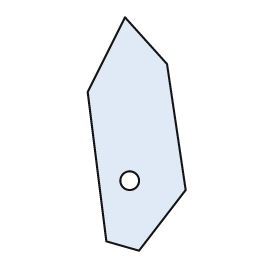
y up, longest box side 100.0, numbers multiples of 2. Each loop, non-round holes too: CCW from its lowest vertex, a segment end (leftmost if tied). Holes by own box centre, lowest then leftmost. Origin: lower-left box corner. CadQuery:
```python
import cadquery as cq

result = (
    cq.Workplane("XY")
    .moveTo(22.0, 0.0)
    .lineTo(42.0, 26.0)
    .lineTo(34.0, 80.0)
    .lineTo(16.0, 100.0)
    .lineTo(0.0, 68.0)
    .lineTo(8.0, 4.0)
    .close()
    .moveTo(18.0, 30.0)
    .circle(4.0)
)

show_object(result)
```